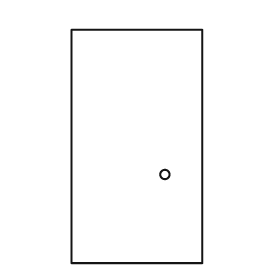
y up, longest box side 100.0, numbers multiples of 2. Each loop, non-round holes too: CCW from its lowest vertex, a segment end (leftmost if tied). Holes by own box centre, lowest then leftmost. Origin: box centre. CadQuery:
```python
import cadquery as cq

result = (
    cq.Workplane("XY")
    .moveTo(-28.0, -50.0)
    .lineTo(28.0, -50.0)
    .lineTo(28.0, 50.0)
    .lineTo(-28.0, 50.0)
    .close()
    .moveTo(12.0, -12.0)
    .circle(2.0)
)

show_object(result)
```